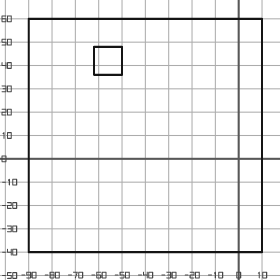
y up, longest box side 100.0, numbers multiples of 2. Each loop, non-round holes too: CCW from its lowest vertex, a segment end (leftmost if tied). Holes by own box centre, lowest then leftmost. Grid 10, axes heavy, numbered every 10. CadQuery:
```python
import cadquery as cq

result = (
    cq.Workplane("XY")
    .moveTo(-90.0, -40.0)
    .lineTo(10.0, -40.0)
    .lineTo(10.0, 60.0)
    .lineTo(-90.0, 60.0)
    .close()
    .moveTo(-62.0, 36.0)
    .lineTo(-50.0, 36.0)
    .lineTo(-50.0, 48.0)
    .lineTo(-62.0, 48.0)
    .close()
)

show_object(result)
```